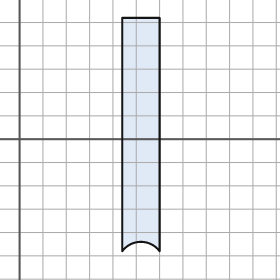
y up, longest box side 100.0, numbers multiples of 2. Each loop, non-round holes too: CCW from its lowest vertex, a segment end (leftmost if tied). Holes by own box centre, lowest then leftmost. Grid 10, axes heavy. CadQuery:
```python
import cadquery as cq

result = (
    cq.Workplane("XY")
    .moveTo(44.0, -48.0)
    .threePointArc((52.0, -44.0), (60.0, -48.0))
    .lineTo(60.0, 52.0)
    .lineTo(44.0, 52.0)
    .close()
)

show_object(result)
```